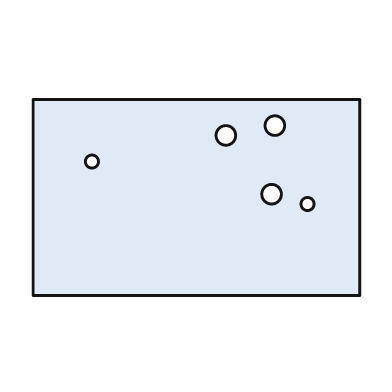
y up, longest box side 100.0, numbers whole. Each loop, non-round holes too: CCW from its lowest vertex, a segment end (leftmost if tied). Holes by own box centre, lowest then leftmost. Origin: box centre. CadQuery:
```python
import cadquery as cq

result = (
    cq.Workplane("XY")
    .moveTo(-50.0, -30.0)
    .lineTo(50.0, -30.0)
    .lineTo(50.0, 30.0)
    .lineTo(-50.0, 30.0)
    .close()
    .moveTo(34.0, -2.0)
    .circle(2.0)
    .moveTo(23.0, 1.0)
    .circle(3.0)
    .moveTo(-32.0, 11.0)
    .circle(2.0)
    .moveTo(9.0, 19.0)
    .circle(3.0)
    .moveTo(24.0, 22.0)
    .circle(3.0)
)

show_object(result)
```